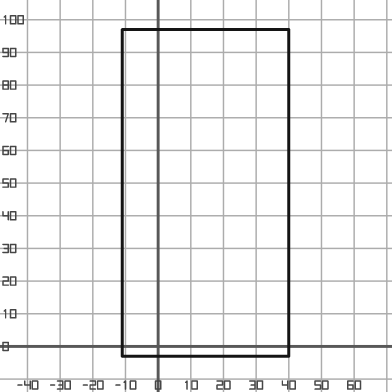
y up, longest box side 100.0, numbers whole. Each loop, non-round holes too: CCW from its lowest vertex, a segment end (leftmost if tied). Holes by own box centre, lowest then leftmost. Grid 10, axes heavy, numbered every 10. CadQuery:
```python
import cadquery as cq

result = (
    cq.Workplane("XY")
    .moveTo(-11.0, -3.0)
    .lineTo(40.0, -3.0)
    .lineTo(40.0, 97.0)
    .lineTo(-11.0, 97.0)
    .close()
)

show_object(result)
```